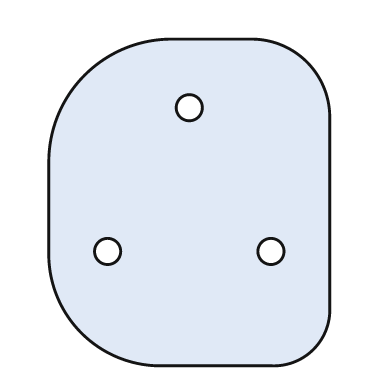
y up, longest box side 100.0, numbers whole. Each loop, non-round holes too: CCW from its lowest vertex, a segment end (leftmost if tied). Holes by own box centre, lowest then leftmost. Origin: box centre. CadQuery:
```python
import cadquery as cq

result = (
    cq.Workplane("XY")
    .moveTo(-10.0, -50.0)
    .lineTo(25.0, -50.0)
    .threePointArc((38.0, -45.0), (43.0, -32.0))
    .lineTo(43.0, 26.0)
    .threePointArc((36.0, 43.0), (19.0, 50.0))
    .lineTo(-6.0, 50.0)
    .threePointArc((-32.0, 39.0), (-43.0, 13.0))
    .lineTo(-43.0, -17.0)
    .threePointArc((-33.0, -40.0), (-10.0, -50.0))
    .close()
    .moveTo(-25.0, -15.0)
    .circle(4.0)
    .moveTo(25.0, -15.0)
    .circle(4.0)
    .moveTo(0.0, 29.0)
    .circle(4.0)
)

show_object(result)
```